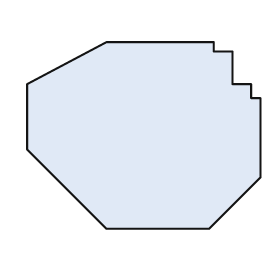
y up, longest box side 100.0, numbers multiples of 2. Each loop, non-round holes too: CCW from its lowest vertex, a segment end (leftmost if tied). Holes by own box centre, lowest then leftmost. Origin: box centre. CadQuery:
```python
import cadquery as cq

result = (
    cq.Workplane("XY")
    .moveTo(-16.0, -40.0)
    .lineTo(28.0, -40.0)
    .lineTo(50.0, -18.0)
    .lineTo(50.0, 16.0)
    .lineTo(46.0, 16.0)
    .lineTo(46.0, 22.0)
    .lineTo(38.0, 22.0)
    .lineTo(38.0, 36.0)
    .lineTo(30.0, 36.0)
    .lineTo(30.0, 40.0)
    .lineTo(-16.0, 40.0)
    .lineTo(-50.0, 22.0)
    .lineTo(-50.0, -6.0)
    .close()
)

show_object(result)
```